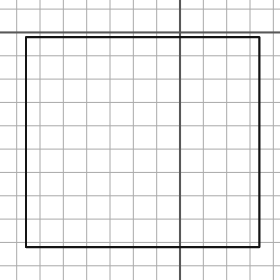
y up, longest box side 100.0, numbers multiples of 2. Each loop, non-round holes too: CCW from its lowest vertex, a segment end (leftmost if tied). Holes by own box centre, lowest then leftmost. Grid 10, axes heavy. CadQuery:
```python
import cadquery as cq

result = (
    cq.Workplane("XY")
    .moveTo(-66.0, -92.0)
    .lineTo(34.0, -92.0)
    .lineTo(34.0, -2.0)
    .lineTo(-66.0, -2.0)
    .close()
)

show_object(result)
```